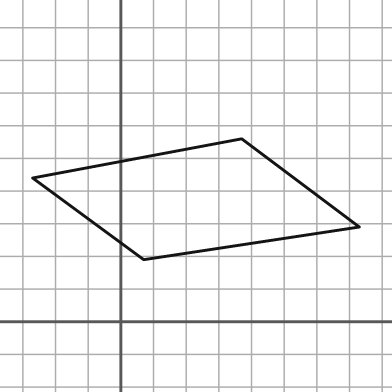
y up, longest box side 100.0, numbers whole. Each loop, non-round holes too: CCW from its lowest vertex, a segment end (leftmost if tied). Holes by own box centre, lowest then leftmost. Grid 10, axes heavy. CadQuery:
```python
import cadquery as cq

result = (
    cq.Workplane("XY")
    .moveTo(7.0, 19.0)
    .lineTo(73.0, 29.0)
    .lineTo(37.0, 56.0)
    .lineTo(-27.0, 44.0)
    .close()
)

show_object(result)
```